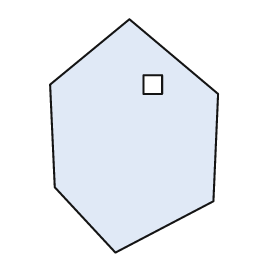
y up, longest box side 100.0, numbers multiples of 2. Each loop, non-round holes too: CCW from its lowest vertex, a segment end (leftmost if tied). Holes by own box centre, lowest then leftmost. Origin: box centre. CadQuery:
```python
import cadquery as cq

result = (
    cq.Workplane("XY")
    .moveTo(-8.0, -50.0)
    .lineTo(34.0, -28.0)
    .lineTo(36.0, 18.0)
    .lineTo(-2.0, 50.0)
    .lineTo(-36.0, 22.0)
    .lineTo(-34.0, -22.0)
    .close()
    .moveTo(4.0, 18.0)
    .lineTo(12.0, 18.0)
    .lineTo(12.0, 26.0)
    .lineTo(4.0, 26.0)
    .close()
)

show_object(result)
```